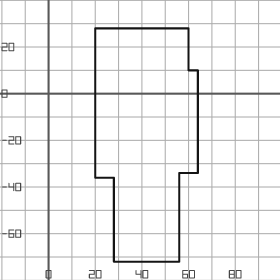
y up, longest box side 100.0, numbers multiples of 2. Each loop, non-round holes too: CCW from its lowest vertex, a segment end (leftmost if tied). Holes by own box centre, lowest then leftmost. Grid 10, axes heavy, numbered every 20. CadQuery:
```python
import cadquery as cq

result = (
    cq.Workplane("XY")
    .moveTo(28.0, -72.0)
    .lineTo(56.0, -72.0)
    .lineTo(56.0, -34.0)
    .lineTo(64.0, -34.0)
    .lineTo(64.0, 10.0)
    .lineTo(60.0, 10.0)
    .lineTo(60.0, 28.0)
    .lineTo(20.0, 28.0)
    .lineTo(20.0, -36.0)
    .lineTo(28.0, -36.0)
    .close()
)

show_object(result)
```